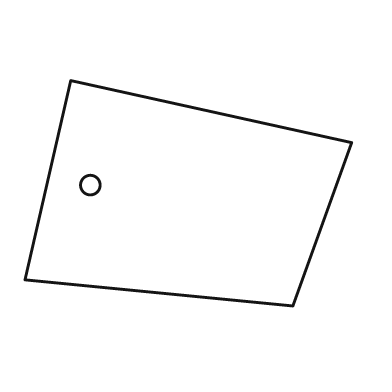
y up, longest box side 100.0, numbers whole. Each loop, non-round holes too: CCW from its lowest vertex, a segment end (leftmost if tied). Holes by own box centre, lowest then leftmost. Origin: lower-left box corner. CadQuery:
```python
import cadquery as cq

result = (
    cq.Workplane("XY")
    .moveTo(82.0, 0.0)
    .lineTo(100.0, 50.0)
    .lineTo(14.0, 69.0)
    .lineTo(0.0, 8.0)
    .close()
    .moveTo(20.0, 37.0)
    .circle(3.0)
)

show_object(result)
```